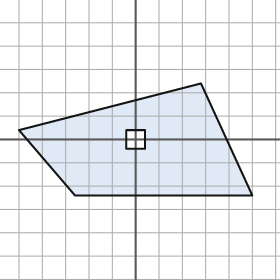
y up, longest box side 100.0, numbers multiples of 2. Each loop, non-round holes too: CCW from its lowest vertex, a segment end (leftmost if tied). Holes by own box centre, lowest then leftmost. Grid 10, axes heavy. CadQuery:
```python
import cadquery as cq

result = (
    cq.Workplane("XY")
    .moveTo(-26.0, -24.0)
    .lineTo(50.0, -24.0)
    .lineTo(28.0, 24.0)
    .lineTo(-50.0, 4.0)
    .close()
    .moveTo(-4.0, -4.0)
    .lineTo(4.0, -4.0)
    .lineTo(4.0, 4.0)
    .lineTo(-4.0, 4.0)
    .close()
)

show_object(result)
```